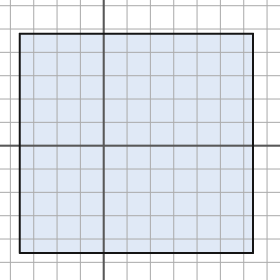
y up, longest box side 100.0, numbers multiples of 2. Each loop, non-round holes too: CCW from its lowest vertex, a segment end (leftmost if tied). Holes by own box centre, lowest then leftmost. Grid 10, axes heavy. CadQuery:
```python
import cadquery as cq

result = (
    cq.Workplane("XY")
    .moveTo(-36.0, -46.0)
    .lineTo(64.0, -46.0)
    .lineTo(64.0, 48.0)
    .lineTo(-36.0, 48.0)
    .close()
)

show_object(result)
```